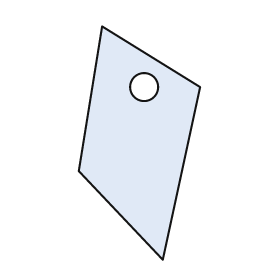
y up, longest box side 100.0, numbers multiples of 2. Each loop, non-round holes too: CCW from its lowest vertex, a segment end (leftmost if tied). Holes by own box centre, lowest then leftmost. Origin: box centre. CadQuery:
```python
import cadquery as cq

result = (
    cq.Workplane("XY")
    .moveTo(10.0, -50.0)
    .lineTo(26.0, 24.0)
    .lineTo(-16.0, 50.0)
    .lineTo(-26.0, -12.0)
    .close()
    .moveTo(2.0, 24.0)
    .circle(6.0)
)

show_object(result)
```